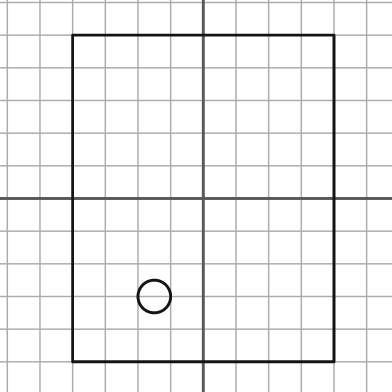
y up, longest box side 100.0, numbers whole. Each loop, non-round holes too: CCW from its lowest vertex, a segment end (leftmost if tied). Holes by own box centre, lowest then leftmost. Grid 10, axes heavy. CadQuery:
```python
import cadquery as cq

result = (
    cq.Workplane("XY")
    .moveTo(-40.0, -50.0)
    .lineTo(40.0, -50.0)
    .lineTo(40.0, 50.0)
    .lineTo(-40.0, 50.0)
    .close()
    .moveTo(-15.0, -30.0)
    .circle(5.0)
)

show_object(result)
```